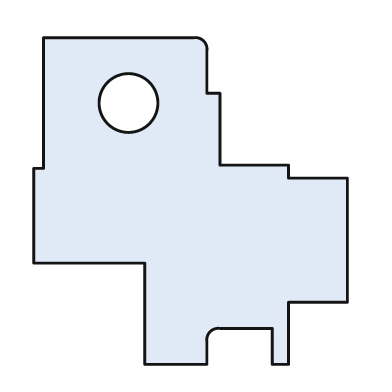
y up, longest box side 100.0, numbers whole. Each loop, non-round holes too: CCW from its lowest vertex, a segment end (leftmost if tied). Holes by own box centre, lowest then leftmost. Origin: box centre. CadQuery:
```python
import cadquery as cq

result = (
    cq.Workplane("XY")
    .moveTo(-14.0, -50.0)
    .lineTo(5.0, -50.0)
    .lineTo(5.0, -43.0)
    .threePointArc((6.0, -40.0), (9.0, -39.0))
    .lineTo(25.0, -39.0)
    .lineTo(25.0, -50.0)
    .lineTo(30.0, -50.0)
    .lineTo(30.0, -31.0)
    .lineTo(48.0, -31.0)
    .lineTo(48.0, 7.0)
    .lineTo(30.0, 7.0)
    .lineTo(30.0, 11.0)
    .lineTo(9.0, 11.0)
    .lineTo(9.0, 33.0)
    .lineTo(5.0, 33.0)
    .lineTo(5.0, 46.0)
    .threePointArc((4.0, 49.0), (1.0, 50.0))
    .lineTo(-45.0, 50.0)
    .lineTo(-45.0, 10.0)
    .lineTo(-48.0, 10.0)
    .lineTo(-48.0, -19.0)
    .lineTo(-14.0, -19.0)
    .close()
    .moveTo(-19.0, 30.0)
    .circle(9.0)
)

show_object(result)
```